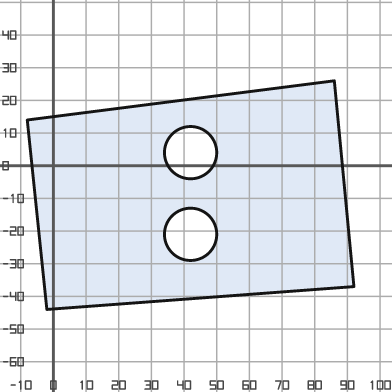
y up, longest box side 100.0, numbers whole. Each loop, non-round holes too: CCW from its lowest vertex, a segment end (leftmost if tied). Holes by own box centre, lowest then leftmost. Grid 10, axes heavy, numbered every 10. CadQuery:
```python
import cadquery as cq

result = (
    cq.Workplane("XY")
    .moveTo(-2.0, -44.0)
    .lineTo(92.0, -37.0)
    .lineTo(86.0, 26.0)
    .lineTo(-8.0, 14.0)
    .close()
    .moveTo(42.0, -21.0)
    .circle(8.0)
    .moveTo(42.0, 4.0)
    .circle(8.0)
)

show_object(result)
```